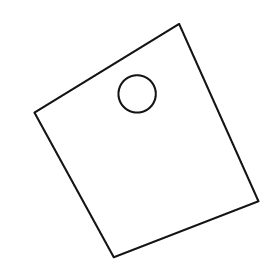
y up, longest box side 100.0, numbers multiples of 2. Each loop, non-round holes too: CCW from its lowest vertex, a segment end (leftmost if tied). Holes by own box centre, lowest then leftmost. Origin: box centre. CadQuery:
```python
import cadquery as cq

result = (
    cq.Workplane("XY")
    .moveTo(-14.0, -50.0)
    .lineTo(48.0, -26.0)
    .lineTo(14.0, 50.0)
    .lineTo(-48.0, 12.0)
    .close()
    .moveTo(-4.0, 20.0)
    .circle(8.0)
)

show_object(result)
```